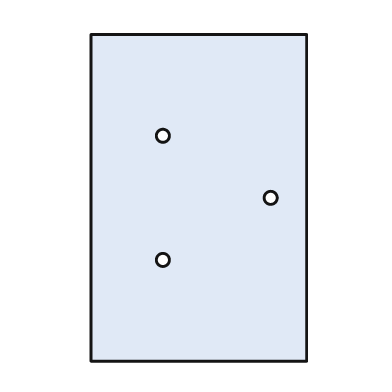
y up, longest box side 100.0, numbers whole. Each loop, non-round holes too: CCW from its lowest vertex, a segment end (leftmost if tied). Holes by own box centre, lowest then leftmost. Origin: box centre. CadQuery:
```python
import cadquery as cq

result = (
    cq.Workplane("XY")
    .moveTo(-33.0, -50.0)
    .lineTo(33.0, -50.0)
    .lineTo(33.0, 50.0)
    .lineTo(-33.0, 50.0)
    .close()
    .moveTo(-11.0, -19.0)
    .circle(2.0)
    .moveTo(22.0, 0.0)
    .circle(2.0)
    .moveTo(-11.0, 19.0)
    .circle(2.0)
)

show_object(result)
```